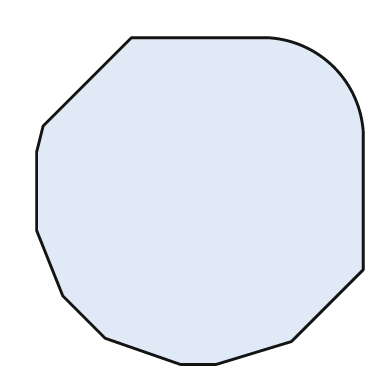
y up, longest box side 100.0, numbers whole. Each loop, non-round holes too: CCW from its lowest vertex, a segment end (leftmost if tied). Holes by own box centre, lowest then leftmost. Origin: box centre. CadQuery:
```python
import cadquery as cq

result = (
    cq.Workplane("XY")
    .moveTo(-6.0, -50.0)
    .lineTo(5.0, -50.0)
    .lineTo(28.0, -43.0)
    .lineTo(50.0, -21.0)
    .lineTo(50.0, 21.0)
    .threePointArc((41.0, 41.0), (21.0, 50.0))
    .lineTo(-21.0, 50.0)
    .lineTo(-48.0, 23.0)
    .lineTo(-50.0, 15.0)
    .lineTo(-50.0, -9.0)
    .lineTo(-42.0, -29.0)
    .lineTo(-29.0, -42.0)
    .close()
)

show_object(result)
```